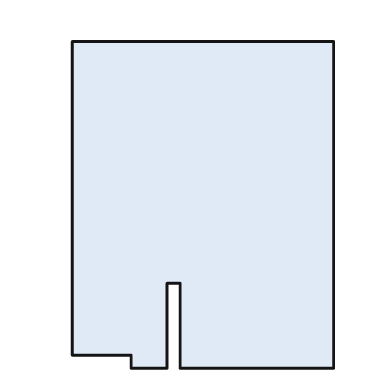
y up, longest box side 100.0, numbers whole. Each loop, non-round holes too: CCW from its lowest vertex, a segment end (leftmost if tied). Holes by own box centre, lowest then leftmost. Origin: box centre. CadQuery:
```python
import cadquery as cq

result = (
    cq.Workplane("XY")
    .moveTo(-22.0, -50.0)
    .lineTo(-11.0, -50.0)
    .lineTo(-11.0, -24.0)
    .lineTo(-7.0, -24.0)
    .lineTo(-7.0, -50.0)
    .lineTo(40.0, -50.0)
    .lineTo(40.0, 50.0)
    .lineTo(-40.0, 50.0)
    .lineTo(-40.0, -46.0)
    .lineTo(-22.0, -46.0)
    .close()
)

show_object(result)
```